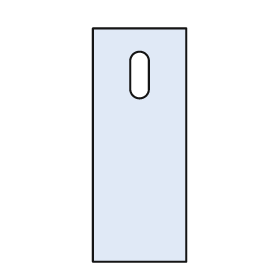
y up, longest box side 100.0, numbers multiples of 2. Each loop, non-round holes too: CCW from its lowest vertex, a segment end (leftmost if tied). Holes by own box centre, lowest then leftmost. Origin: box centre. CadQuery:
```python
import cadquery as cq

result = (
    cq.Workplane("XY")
    .moveTo(-20.0, -50.0)
    .lineTo(20.0, -50.0)
    .lineTo(20.0, 50.0)
    .lineTo(-20.0, 50.0)
    .close()
    .moveTo(-4.0, 24.0)
    .threePointArc((0.0, 20.0), (4.0, 24.0))
    .lineTo(4.0, 36.0)
    .threePointArc((0.0, 40.0), (-4.0, 36.0))
    .close()
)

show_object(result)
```